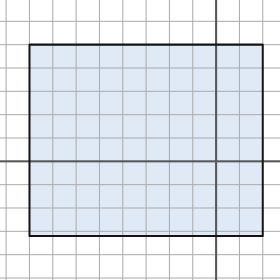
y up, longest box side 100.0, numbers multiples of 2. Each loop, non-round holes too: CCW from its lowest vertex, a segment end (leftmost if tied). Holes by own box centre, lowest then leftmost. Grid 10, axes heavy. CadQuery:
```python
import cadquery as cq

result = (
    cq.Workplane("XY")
    .moveTo(-80.0, -32.0)
    .lineTo(20.0, -32.0)
    .lineTo(20.0, 50.0)
    .lineTo(-80.0, 50.0)
    .close()
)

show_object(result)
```